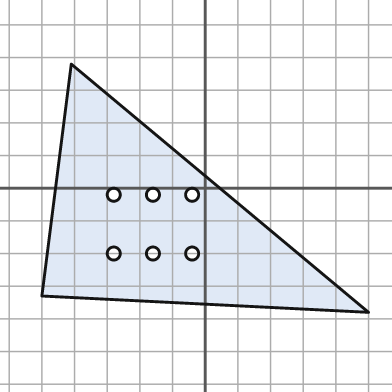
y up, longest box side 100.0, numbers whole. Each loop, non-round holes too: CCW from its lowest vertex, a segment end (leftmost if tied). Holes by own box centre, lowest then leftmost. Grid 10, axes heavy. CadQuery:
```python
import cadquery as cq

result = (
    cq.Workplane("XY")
    .moveTo(50.0, -38.0)
    .lineTo(-41.0, 38.0)
    .lineTo(-50.0, -33.0)
    .close()
    .moveTo(-28.0, -20.0)
    .circle(2.0)
    .moveTo(-16.0, -20.0)
    .circle(2.0)
    .moveTo(-4.0, -20.0)
    .circle(2.0)
    .moveTo(-28.0, -2.0)
    .circle(2.0)
    .moveTo(-16.0, -2.0)
    .circle(2.0)
    .moveTo(-4.0, -2.0)
    .circle(2.0)
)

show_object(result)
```